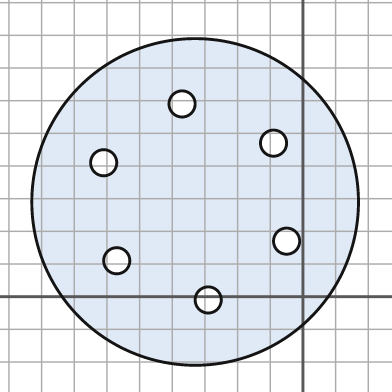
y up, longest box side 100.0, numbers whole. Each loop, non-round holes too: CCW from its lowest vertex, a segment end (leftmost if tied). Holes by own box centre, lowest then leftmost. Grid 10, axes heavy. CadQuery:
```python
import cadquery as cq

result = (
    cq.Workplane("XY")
    .moveTo(-33.0, 29.0)
    .circle(50.0)
    .moveTo(-29.0, -1.0)
    .circle(4.0)
    .moveTo(-57.0, 11.0)
    .circle(4.0)
    .moveTo(-5.0, 17.0)
    .circle(4.0)
    .moveTo(-61.0, 41.0)
    .circle(4.0)
    .moveTo(-9.0, 47.0)
    .circle(4.0)
    .moveTo(-37.0, 59.0)
    .circle(4.0)
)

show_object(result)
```